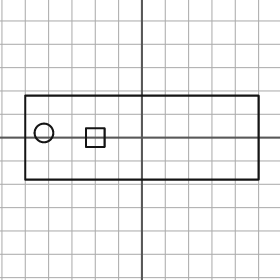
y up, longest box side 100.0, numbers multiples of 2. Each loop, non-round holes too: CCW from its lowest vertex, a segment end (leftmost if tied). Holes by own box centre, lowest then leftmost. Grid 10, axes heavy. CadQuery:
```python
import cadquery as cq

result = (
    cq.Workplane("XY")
    .moveTo(-50.0, -18.0)
    .lineTo(50.0, -18.0)
    .lineTo(50.0, 18.0)
    .lineTo(-50.0, 18.0)
    .close()
    .moveTo(-24.0, -4.0)
    .lineTo(-16.0, -4.0)
    .lineTo(-16.0, 4.0)
    .lineTo(-24.0, 4.0)
    .close()
    .moveTo(-42.0, 2.0)
    .circle(4.0)
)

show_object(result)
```